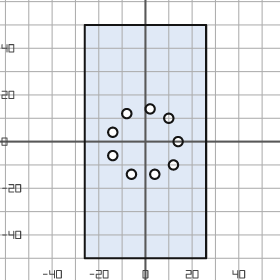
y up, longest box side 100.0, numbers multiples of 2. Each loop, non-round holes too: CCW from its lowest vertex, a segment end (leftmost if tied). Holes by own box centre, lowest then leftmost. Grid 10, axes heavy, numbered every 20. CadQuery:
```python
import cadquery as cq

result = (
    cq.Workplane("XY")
    .moveTo(-26.0, -50.0)
    .lineTo(26.0, -50.0)
    .lineTo(26.0, 50.0)
    .lineTo(-26.0, 50.0)
    .close()
    .moveTo(-6.0, -14.0)
    .circle(2.0)
    .moveTo(4.0, -14.0)
    .circle(2.0)
    .moveTo(12.0, -10.0)
    .circle(2.0)
    .moveTo(-14.0, -6.0)
    .circle(2.0)
    .moveTo(14.0, 0.0)
    .circle(2.0)
    .moveTo(-14.0, 4.0)
    .circle(2.0)
    .moveTo(10.0, 10.0)
    .circle(2.0)
    .moveTo(-8.0, 12.0)
    .circle(2.0)
    .moveTo(2.0, 14.0)
    .circle(2.0)
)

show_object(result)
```